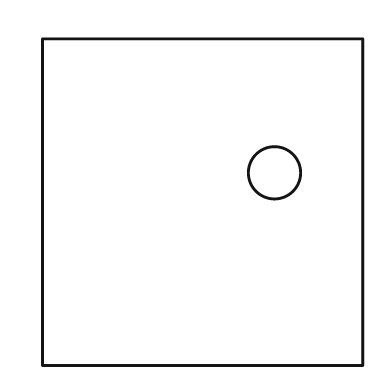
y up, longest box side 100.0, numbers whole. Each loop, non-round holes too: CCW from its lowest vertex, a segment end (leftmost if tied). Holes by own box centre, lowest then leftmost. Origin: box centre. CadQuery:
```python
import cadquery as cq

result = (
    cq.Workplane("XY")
    .moveTo(-49.0, -50.0)
    .lineTo(49.0, -50.0)
    .lineTo(49.0, 50.0)
    .lineTo(-49.0, 50.0)
    .close()
    .moveTo(22.0, 9.0)
    .circle(8.0)
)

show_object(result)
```